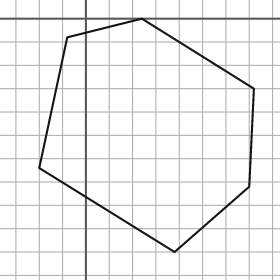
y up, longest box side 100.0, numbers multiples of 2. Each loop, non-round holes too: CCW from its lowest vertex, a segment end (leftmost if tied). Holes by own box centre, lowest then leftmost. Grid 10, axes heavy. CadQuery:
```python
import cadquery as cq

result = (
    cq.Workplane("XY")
    .moveTo(38.0, -100.0)
    .lineTo(70.0, -72.0)
    .lineTo(72.0, -30.0)
    .lineTo(24.0, 0.0)
    .lineTo(-8.0, -8.0)
    .lineTo(-20.0, -64.0)
    .close()
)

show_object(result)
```